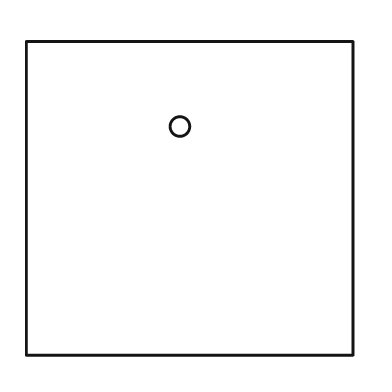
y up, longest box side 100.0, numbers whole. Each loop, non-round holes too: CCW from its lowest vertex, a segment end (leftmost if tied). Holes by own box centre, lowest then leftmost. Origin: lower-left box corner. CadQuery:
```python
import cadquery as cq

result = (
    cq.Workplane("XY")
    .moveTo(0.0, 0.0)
    .lineTo(100.0, 0.0)
    .lineTo(100.0, 96.0)
    .lineTo(0.0, 96.0)
    .close()
    .moveTo(47.0, 70.0)
    .circle(3.0)
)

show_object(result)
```